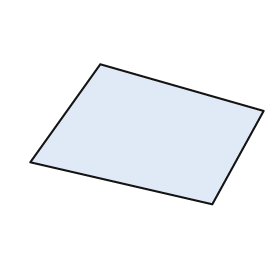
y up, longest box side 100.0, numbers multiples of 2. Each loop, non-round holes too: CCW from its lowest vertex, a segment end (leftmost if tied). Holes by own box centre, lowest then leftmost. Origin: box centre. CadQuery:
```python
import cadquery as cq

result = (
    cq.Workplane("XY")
    .moveTo(28.0, -30.0)
    .lineTo(50.0, 10.0)
    .lineTo(-20.0, 30.0)
    .lineTo(-50.0, -12.0)
    .close()
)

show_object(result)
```